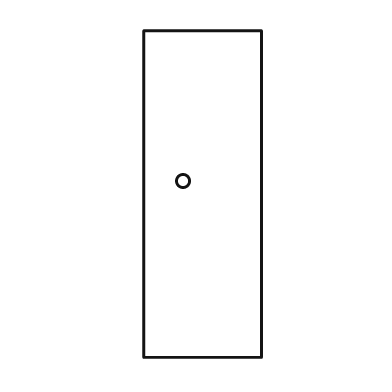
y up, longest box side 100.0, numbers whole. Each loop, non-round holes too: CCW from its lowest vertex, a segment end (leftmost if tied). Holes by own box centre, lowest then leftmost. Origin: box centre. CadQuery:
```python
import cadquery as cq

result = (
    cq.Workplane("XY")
    .moveTo(-18.0, -50.0)
    .lineTo(18.0, -50.0)
    .lineTo(18.0, 50.0)
    .lineTo(-18.0, 50.0)
    .close()
    .moveTo(-6.0, 4.0)
    .circle(2.0)
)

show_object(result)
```